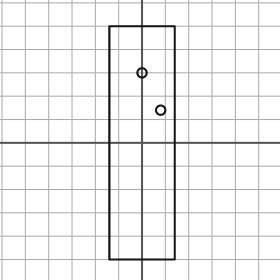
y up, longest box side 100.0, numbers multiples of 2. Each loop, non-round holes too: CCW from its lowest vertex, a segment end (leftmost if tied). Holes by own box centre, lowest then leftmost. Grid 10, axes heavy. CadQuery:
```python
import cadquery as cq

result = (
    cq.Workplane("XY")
    .moveTo(-14.0, -50.0)
    .lineTo(14.0, -50.0)
    .lineTo(14.0, 50.0)
    .lineTo(-14.0, 50.0)
    .close()
    .moveTo(8.0, 14.0)
    .circle(2.0)
    .moveTo(0.0, 30.0)
    .circle(2.0)
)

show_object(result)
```